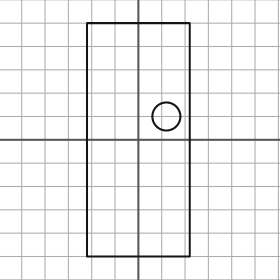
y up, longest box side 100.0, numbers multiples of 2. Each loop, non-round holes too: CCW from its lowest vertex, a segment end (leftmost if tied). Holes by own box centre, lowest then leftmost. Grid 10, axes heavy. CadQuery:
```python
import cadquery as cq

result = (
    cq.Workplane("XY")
    .moveTo(-22.0, -50.0)
    .lineTo(22.0, -50.0)
    .lineTo(22.0, 50.0)
    .lineTo(-22.0, 50.0)
    .close()
    .moveTo(12.0, 10.0)
    .circle(6.0)
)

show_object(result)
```